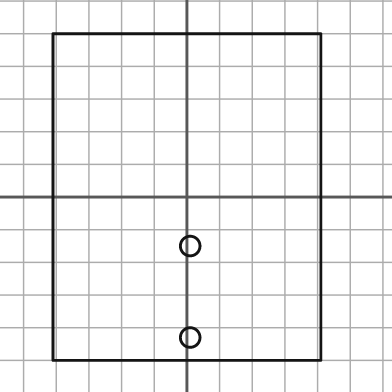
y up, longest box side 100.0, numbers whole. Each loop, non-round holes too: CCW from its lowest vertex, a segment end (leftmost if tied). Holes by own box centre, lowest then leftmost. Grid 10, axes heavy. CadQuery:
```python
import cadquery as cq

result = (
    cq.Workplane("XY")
    .moveTo(-41.0, -50.0)
    .lineTo(41.0, -50.0)
    .lineTo(41.0, 50.0)
    .lineTo(-41.0, 50.0)
    .close()
    .moveTo(1.0, -43.0)
    .circle(3.0)
    .moveTo(1.0, -15.0)
    .circle(3.0)
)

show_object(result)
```